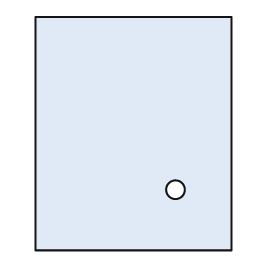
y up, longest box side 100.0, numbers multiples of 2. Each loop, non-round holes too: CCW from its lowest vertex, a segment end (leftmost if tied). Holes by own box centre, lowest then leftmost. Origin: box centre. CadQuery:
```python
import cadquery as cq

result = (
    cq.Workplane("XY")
    .moveTo(-42.0, -50.0)
    .lineTo(42.0, -50.0)
    .lineTo(42.0, 50.0)
    .lineTo(-42.0, 50.0)
    .close()
    .moveTo(18.0, -24.0)
    .circle(4.0)
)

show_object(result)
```